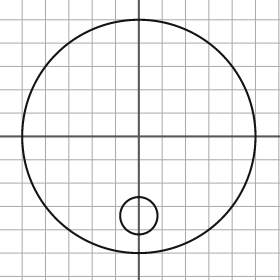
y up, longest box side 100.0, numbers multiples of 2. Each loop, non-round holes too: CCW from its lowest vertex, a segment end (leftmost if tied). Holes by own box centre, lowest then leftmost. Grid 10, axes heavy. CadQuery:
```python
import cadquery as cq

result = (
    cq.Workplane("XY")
    .moveTo(0.0, 0.0)
    .circle(50.0)
    .moveTo(0.0, -34.0)
    .circle(8.0)
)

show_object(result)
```